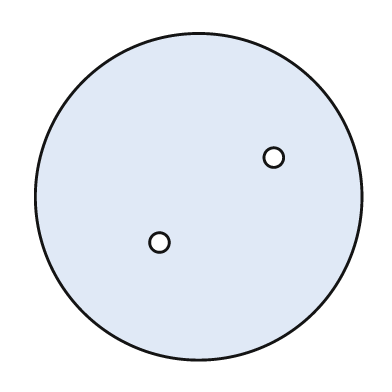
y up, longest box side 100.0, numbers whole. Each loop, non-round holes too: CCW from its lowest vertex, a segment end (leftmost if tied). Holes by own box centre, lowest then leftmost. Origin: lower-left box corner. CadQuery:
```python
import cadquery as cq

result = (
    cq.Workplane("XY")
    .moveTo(50.0, 50.0)
    .circle(50.0)
    .moveTo(38.0, 36.0)
    .circle(3.0)
    .moveTo(73.0, 62.0)
    .circle(3.0)
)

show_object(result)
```